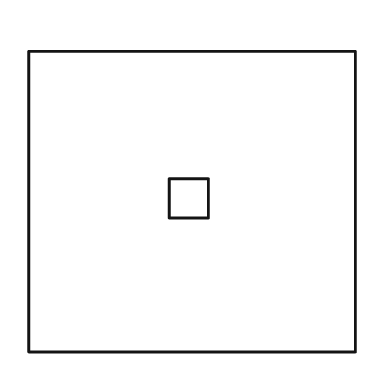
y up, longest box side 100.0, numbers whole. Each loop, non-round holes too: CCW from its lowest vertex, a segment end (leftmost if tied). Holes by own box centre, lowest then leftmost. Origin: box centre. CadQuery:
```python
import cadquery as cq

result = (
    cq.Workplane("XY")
    .moveTo(-50.0, -46.0)
    .lineTo(50.0, -46.0)
    .lineTo(50.0, 46.0)
    .lineTo(-50.0, 46.0)
    .close()
    .moveTo(-7.0, -5.0)
    .lineTo(5.0, -5.0)
    .lineTo(5.0, 7.0)
    .lineTo(-7.0, 7.0)
    .close()
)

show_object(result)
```